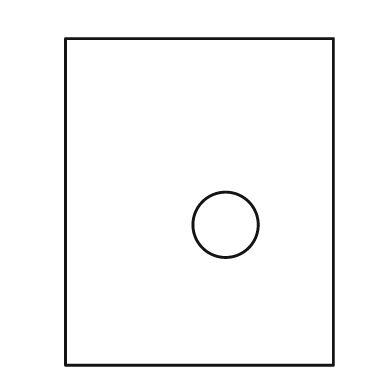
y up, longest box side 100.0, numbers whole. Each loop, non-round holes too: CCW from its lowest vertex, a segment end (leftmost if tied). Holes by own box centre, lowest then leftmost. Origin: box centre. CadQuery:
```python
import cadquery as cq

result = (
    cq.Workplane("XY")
    .moveTo(-41.0, -50.0)
    .lineTo(41.0, -50.0)
    .lineTo(41.0, 50.0)
    .lineTo(-41.0, 50.0)
    .close()
    .moveTo(8.0, -7.0)
    .circle(10.0)
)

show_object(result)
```